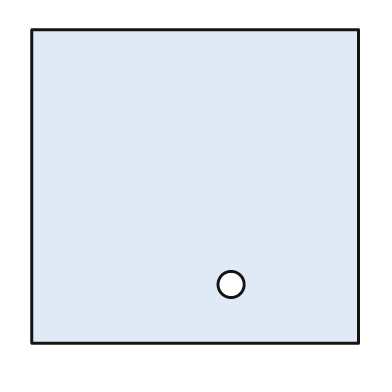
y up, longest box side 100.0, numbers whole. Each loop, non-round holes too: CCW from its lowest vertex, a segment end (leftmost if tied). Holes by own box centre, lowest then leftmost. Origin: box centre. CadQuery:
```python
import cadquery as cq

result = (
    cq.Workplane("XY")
    .moveTo(-50.0, -48.0)
    .lineTo(50.0, -48.0)
    .lineTo(50.0, 48.0)
    .lineTo(-50.0, 48.0)
    .close()
    .moveTo(11.0, -30.0)
    .circle(4.0)
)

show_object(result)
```